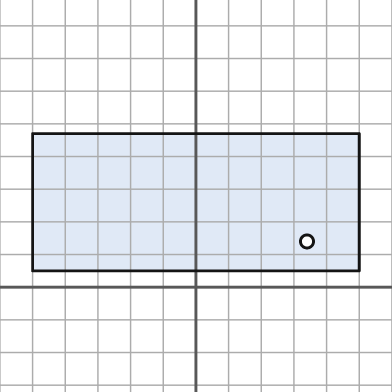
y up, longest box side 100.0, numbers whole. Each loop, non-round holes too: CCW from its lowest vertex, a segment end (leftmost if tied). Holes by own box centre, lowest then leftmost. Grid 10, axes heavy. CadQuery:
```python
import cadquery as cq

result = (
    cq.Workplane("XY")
    .moveTo(-50.0, 5.0)
    .lineTo(50.0, 5.0)
    .lineTo(50.0, 47.0)
    .lineTo(-50.0, 47.0)
    .close()
    .moveTo(34.0, 14.0)
    .circle(2.0)
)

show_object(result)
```